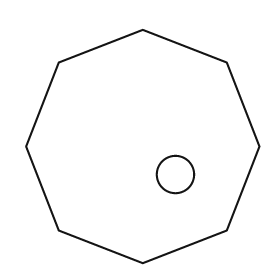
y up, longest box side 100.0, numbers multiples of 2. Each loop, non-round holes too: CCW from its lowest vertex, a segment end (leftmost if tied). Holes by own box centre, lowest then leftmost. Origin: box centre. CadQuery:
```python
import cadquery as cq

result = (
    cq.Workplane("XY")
    .moveTo(0.0, -50.0)
    .lineTo(36.0, -36.0)
    .lineTo(50.0, 0.0)
    .lineTo(36.0, 36.0)
    .lineTo(0.0, 50.0)
    .lineTo(-36.0, 36.0)
    .lineTo(-50.0, 0.0)
    .lineTo(-36.0, -36.0)
    .close()
    .moveTo(14.0, -12.0)
    .circle(8.0)
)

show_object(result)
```